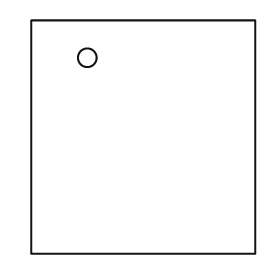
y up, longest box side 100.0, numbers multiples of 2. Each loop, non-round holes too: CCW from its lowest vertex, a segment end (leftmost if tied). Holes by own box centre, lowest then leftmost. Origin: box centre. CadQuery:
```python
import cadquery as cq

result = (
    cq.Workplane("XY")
    .moveTo(-48.0, -50.0)
    .lineTo(48.0, -50.0)
    .lineTo(48.0, 50.0)
    .lineTo(-48.0, 50.0)
    .close()
    .moveTo(-24.0, 34.0)
    .circle(4.0)
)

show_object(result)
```